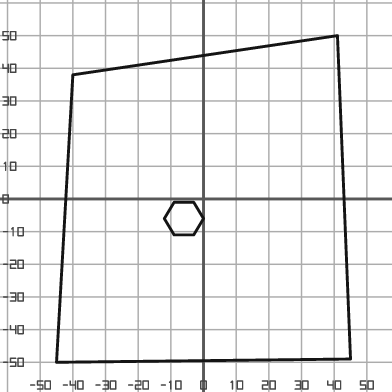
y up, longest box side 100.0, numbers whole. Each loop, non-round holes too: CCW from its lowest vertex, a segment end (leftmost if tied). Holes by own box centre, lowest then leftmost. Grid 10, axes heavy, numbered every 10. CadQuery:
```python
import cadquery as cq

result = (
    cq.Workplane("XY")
    .moveTo(-45.0, -50.0)
    .lineTo(45.0, -49.0)
    .lineTo(41.0, 50.0)
    .lineTo(-40.0, 38.0)
    .close()
    .moveTo(-9.0, -11.0)
    .lineTo(-3.0, -11.0)
    .lineTo(0.0, -6.0)
    .lineTo(-3.0, -1.0)
    .lineTo(-9.0, -1.0)
    .lineTo(-12.0, -6.0)
    .close()
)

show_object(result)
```